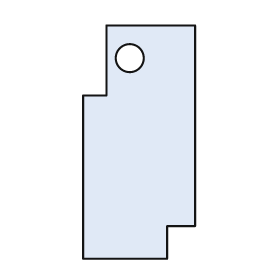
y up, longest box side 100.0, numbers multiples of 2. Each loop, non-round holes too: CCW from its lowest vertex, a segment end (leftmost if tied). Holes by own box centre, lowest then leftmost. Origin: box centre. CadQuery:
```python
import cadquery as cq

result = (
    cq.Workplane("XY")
    .moveTo(-24.0, -50.0)
    .lineTo(12.0, -50.0)
    .lineTo(12.0, -36.0)
    .lineTo(24.0, -36.0)
    .lineTo(24.0, 50.0)
    .lineTo(-14.0, 50.0)
    .lineTo(-14.0, 20.0)
    .lineTo(-24.0, 20.0)
    .close()
    .moveTo(-4.0, 36.0)
    .circle(6.0)
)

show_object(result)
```